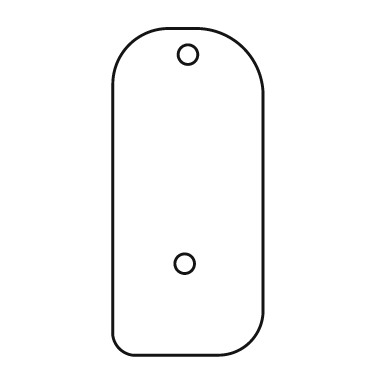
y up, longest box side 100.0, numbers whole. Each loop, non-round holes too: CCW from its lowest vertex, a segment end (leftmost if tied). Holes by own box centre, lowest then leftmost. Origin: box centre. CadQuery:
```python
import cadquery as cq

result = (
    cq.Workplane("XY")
    .moveTo(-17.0, -50.0)
    .lineTo(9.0, -50.0)
    .threePointArc((19.0, -46.0), (23.0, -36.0))
    .lineTo(23.0, 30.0)
    .threePointArc((17.0, 44.0), (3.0, 50.0))
    .lineTo(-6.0, 50.0)
    .threePointArc((-18.0, 45.0), (-23.0, 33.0))
    .lineTo(-23.0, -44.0)
    .threePointArc((-21.0, -48.0), (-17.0, -50.0))
    .close()
    .moveTo(-1.0, -22.0)
    .circle(3.0)
    .moveTo(0.0, 42.0)
    .circle(3.0)
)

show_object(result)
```